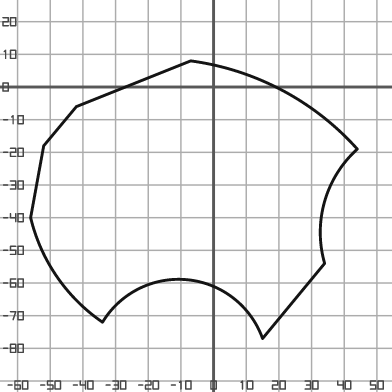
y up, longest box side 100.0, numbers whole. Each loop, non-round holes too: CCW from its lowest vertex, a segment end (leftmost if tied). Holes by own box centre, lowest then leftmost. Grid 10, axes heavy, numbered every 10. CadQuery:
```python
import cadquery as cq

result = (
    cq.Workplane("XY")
    .moveTo(15.0, -77.0)
    .lineTo(34.0, -54.0)
    .threePointArc((34.0, -35.0), (44.0, -19.0))
    .threePointArc((21.0, -1.0), (-7.0, 8.0))
    .lineTo(-42.0, -6.0)
    .lineTo(-52.0, -18.0)
    .lineTo(-56.0, -40.0)
    .threePointArc((-48.0, -58.0), (-34.0, -72.0))
    .threePointArc((-8.0, -59.0), (15.0, -77.0))
    .close()
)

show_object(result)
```